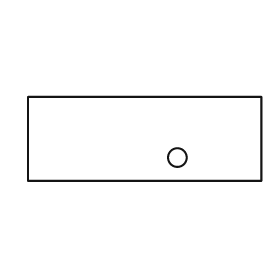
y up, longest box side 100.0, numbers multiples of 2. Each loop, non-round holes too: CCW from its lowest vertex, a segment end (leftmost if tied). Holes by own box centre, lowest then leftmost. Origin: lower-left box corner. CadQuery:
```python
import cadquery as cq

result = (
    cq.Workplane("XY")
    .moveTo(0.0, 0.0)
    .lineTo(100.0, 0.0)
    .lineTo(100.0, 36.0)
    .lineTo(0.0, 36.0)
    .close()
    .moveTo(64.0, 10.0)
    .circle(4.0)
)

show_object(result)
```